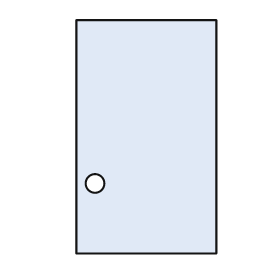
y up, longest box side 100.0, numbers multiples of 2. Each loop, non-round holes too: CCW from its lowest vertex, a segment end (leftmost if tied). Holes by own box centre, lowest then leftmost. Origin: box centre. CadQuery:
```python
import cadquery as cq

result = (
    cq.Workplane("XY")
    .moveTo(-30.0, -50.0)
    .lineTo(30.0, -50.0)
    .lineTo(30.0, 50.0)
    .lineTo(-30.0, 50.0)
    .close()
    .moveTo(-22.0, -20.0)
    .circle(4.0)
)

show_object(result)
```